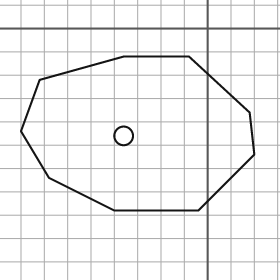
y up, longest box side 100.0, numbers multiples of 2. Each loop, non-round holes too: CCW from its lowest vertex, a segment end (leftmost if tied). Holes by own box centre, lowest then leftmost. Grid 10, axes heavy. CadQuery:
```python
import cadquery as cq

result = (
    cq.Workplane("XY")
    .moveTo(-40.0, -78.0)
    .lineTo(-4.0, -78.0)
    .lineTo(20.0, -54.0)
    .lineTo(18.0, -36.0)
    .lineTo(-8.0, -12.0)
    .lineTo(-36.0, -12.0)
    .lineTo(-72.0, -22.0)
    .lineTo(-80.0, -44.0)
    .lineTo(-68.0, -64.0)
    .close()
    .moveTo(-36.0, -46.0)
    .circle(4.0)
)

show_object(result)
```